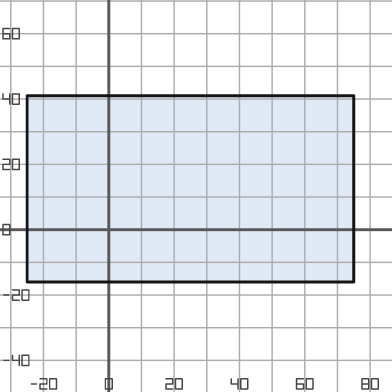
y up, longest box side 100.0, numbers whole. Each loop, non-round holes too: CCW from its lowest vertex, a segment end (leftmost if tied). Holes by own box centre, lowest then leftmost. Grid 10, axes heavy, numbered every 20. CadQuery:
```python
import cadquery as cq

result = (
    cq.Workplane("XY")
    .moveTo(-25.0, -16.0)
    .lineTo(75.0, -16.0)
    .lineTo(75.0, 41.0)
    .lineTo(-25.0, 41.0)
    .close()
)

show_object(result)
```